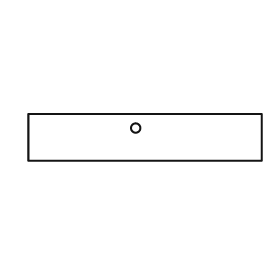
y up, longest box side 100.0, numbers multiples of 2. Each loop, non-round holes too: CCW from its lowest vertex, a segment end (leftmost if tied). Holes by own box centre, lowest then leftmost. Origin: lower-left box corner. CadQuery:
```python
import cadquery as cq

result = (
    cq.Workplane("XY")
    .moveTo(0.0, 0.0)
    .lineTo(100.0, 0.0)
    .lineTo(100.0, 20.0)
    .lineTo(0.0, 20.0)
    .close()
    .moveTo(46.0, 14.0)
    .circle(2.0)
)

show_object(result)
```